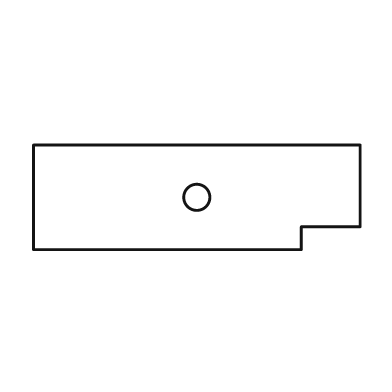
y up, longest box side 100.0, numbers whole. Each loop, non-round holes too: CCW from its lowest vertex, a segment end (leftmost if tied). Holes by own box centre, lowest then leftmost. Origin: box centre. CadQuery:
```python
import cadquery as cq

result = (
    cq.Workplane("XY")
    .moveTo(-50.0, -16.0)
    .lineTo(32.0, -16.0)
    .lineTo(32.0, -9.0)
    .lineTo(50.0, -9.0)
    .lineTo(50.0, 16.0)
    .lineTo(-50.0, 16.0)
    .close()
    .moveTo(0.0, 0.0)
    .circle(4.0)
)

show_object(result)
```